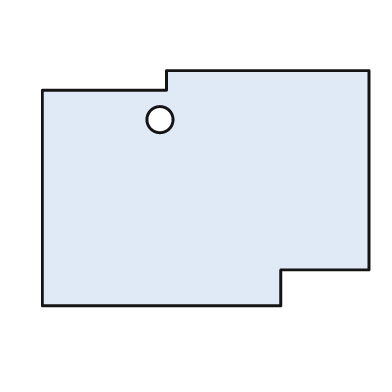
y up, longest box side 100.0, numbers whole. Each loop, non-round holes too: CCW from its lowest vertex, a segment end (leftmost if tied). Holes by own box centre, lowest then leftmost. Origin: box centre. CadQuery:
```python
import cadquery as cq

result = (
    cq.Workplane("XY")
    .moveTo(-50.0, -36.0)
    .lineTo(23.0, -36.0)
    .lineTo(23.0, -25.0)
    .lineTo(50.0, -25.0)
    .lineTo(50.0, 36.0)
    .lineTo(-12.0, 36.0)
    .lineTo(-12.0, 30.0)
    .lineTo(-50.0, 30.0)
    .close()
    .moveTo(-14.0, 21.0)
    .circle(4.0)
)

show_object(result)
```